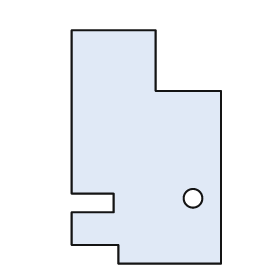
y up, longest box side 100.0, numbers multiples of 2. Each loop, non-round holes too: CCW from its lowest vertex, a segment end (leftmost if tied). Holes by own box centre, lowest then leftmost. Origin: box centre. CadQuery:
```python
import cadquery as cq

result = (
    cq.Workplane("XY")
    .moveTo(-12.0, -50.0)
    .lineTo(32.0, -50.0)
    .lineTo(32.0, 24.0)
    .lineTo(4.0, 24.0)
    .lineTo(4.0, 50.0)
    .lineTo(-32.0, 50.0)
    .lineTo(-32.0, -20.0)
    .lineTo(-14.0, -20.0)
    .lineTo(-14.0, -28.0)
    .lineTo(-32.0, -28.0)
    .lineTo(-32.0, -42.0)
    .lineTo(-12.0, -42.0)
    .close()
    .moveTo(20.0, -22.0)
    .circle(4.0)
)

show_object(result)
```